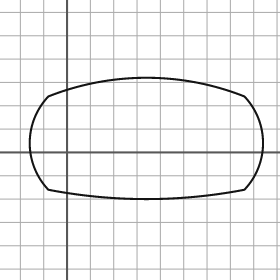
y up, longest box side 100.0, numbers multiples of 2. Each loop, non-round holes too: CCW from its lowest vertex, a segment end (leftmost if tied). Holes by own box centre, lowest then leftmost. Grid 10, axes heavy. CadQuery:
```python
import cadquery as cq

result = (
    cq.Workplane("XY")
    .moveTo(-8.0, -16.0)
    .threePointArc((34.0, -20.0), (76.0, -16.0))
    .threePointArc((84.0, 4.0), (76.0, 24.0))
    .threePointArc((34.0, 32.0), (-8.0, 24.0))
    .threePointArc((-16.0, 4.0), (-8.0, -16.0))
    .close()
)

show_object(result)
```